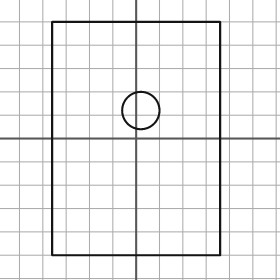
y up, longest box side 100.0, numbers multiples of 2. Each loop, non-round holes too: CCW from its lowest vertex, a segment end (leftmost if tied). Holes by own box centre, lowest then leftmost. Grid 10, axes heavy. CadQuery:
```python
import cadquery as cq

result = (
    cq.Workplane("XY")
    .moveTo(-36.0, -50.0)
    .lineTo(36.0, -50.0)
    .lineTo(36.0, 50.0)
    .lineTo(-36.0, 50.0)
    .close()
    .moveTo(2.0, 12.0)
    .circle(8.0)
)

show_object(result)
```